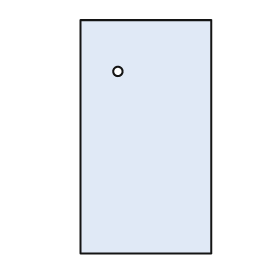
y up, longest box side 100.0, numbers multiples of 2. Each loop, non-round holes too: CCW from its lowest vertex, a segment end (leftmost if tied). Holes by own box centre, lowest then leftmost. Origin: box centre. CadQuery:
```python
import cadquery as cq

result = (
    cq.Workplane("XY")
    .moveTo(-28.0, -50.0)
    .lineTo(28.0, -50.0)
    .lineTo(28.0, 50.0)
    .lineTo(-28.0, 50.0)
    .close()
    .moveTo(-12.0, 28.0)
    .circle(2.0)
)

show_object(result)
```